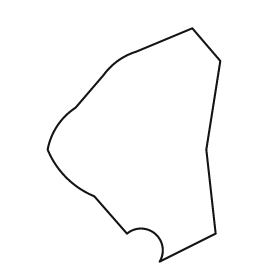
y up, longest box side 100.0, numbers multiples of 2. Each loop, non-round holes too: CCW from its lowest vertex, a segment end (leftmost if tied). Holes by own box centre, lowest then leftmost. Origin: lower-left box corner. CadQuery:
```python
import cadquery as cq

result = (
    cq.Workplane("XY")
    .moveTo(48.0, 0.0)
    .lineTo(72.0, 12.0)
    .lineTo(68.0, 48.0)
    .lineTo(74.0, 86.0)
    .lineTo(62.0, 100.0)
    .lineTo(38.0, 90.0)
    .threePointArc((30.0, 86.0), (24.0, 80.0))
    .lineTo(12.0, 66.0)
    .threePointArc((4.0, 58.0), (0.0, 48.0))
    .threePointArc((8.0, 36.0), (20.0, 28.0))
    .lineTo(34.0, 12.0)
    .threePointArc((46.0, 12.0), (48.0, 0.0))
    .close()
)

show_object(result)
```